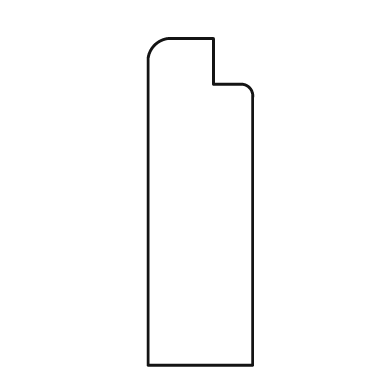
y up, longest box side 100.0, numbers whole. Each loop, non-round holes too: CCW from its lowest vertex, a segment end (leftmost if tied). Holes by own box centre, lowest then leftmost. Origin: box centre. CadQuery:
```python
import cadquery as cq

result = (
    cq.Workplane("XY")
    .moveTo(-16.0, -50.0)
    .lineTo(16.0, -50.0)
    .lineTo(16.0, 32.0)
    .threePointArc((15.0, 35.0), (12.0, 36.0))
    .lineTo(4.0, 36.0)
    .lineTo(4.0, 50.0)
    .lineTo(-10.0, 50.0)
    .threePointArc((-14.0, 48.0), (-16.0, 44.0))
    .close()
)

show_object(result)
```